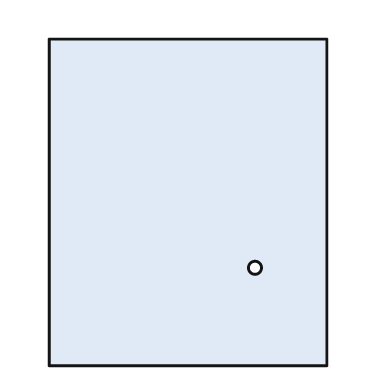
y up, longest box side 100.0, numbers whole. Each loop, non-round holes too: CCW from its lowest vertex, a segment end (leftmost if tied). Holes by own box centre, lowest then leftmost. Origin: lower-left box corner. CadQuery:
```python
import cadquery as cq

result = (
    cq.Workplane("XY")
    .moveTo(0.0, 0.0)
    .lineTo(85.0, 0.0)
    .lineTo(85.0, 100.0)
    .lineTo(0.0, 100.0)
    .close()
    .moveTo(63.0, 30.0)
    .circle(2.0)
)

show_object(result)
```